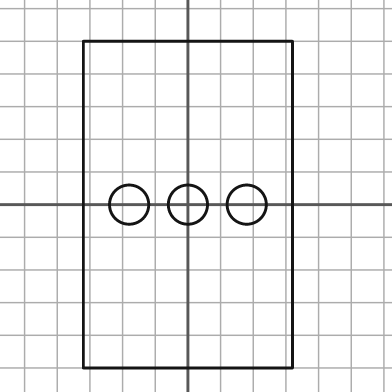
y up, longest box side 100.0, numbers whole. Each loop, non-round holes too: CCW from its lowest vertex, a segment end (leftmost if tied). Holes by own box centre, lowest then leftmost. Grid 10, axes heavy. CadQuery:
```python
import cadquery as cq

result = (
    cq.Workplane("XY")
    .moveTo(-32.0, -50.0)
    .lineTo(32.0, -50.0)
    .lineTo(32.0, 50.0)
    .lineTo(-32.0, 50.0)
    .close()
    .moveTo(-18.0, 0.0)
    .circle(6.0)
    .moveTo(0.0, 0.0)
    .circle(6.0)
    .moveTo(18.0, 0.0)
    .circle(6.0)
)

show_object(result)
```